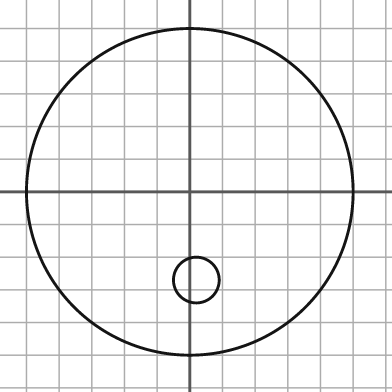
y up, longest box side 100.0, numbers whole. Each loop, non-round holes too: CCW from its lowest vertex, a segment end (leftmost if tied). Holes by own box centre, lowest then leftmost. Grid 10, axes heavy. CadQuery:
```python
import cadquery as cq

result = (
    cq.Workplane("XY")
    .moveTo(0.0, 0.0)
    .circle(50.0)
    .moveTo(2.0, -27.0)
    .circle(7.0)
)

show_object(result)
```